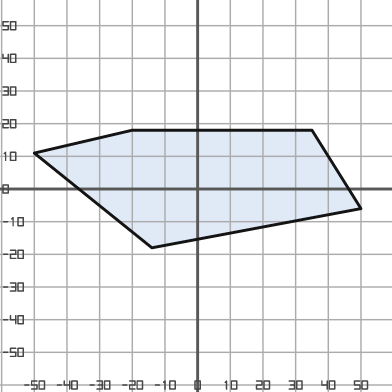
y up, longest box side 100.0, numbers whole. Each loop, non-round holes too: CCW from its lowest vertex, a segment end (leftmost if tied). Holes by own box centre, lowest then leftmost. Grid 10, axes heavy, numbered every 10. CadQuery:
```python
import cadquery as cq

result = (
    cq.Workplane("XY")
    .moveTo(-14.0, -18.0)
    .lineTo(50.0, -6.0)
    .lineTo(35.0, 18.0)
    .lineTo(-20.0, 18.0)
    .lineTo(-50.0, 11.0)
    .close()
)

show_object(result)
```